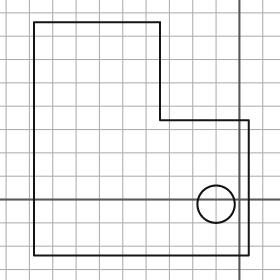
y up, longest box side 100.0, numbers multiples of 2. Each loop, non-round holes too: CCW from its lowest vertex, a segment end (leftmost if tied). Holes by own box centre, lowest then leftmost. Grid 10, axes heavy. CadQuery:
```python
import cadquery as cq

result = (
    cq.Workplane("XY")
    .moveTo(-88.0, -24.0)
    .lineTo(4.0, -24.0)
    .lineTo(4.0, 34.0)
    .lineTo(-34.0, 34.0)
    .lineTo(-34.0, 76.0)
    .lineTo(-88.0, 76.0)
    .close()
    .moveTo(-10.0, -2.0)
    .circle(8.0)
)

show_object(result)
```